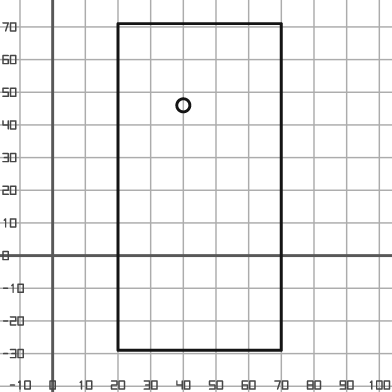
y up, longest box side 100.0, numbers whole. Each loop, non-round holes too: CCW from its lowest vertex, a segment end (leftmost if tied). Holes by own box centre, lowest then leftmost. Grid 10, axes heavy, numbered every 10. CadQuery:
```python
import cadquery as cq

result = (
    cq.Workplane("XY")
    .moveTo(20.0, -29.0)
    .lineTo(70.0, -29.0)
    .lineTo(70.0, 71.0)
    .lineTo(20.0, 71.0)
    .close()
    .moveTo(40.0, 46.0)
    .circle(2.0)
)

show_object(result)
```